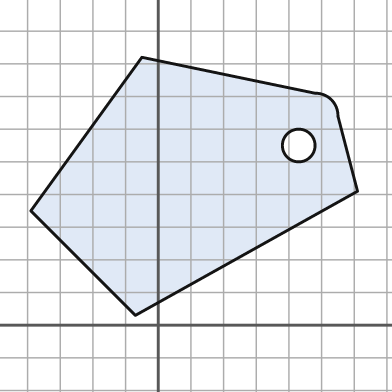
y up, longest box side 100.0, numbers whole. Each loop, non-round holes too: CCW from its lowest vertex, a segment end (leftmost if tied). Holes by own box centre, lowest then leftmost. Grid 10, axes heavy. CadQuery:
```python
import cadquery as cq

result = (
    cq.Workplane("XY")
    .moveTo(-7.0, 3.0)
    .lineTo(61.0, 41.0)
    .lineTo(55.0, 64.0)
    .threePointArc((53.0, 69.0), (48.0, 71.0))
    .lineTo(-5.0, 82.0)
    .lineTo(-39.0, 35.0)
    .close()
    .moveTo(43.0, 55.0)
    .circle(5.0)
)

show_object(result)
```